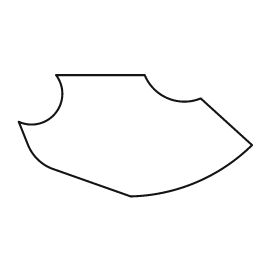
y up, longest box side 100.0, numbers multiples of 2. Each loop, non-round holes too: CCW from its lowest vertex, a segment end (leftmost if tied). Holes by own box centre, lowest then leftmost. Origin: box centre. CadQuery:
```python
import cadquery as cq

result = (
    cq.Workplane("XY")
    .moveTo(-2.0, -26.0)
    .threePointArc((26.0, -20.0), (50.0, -4.0))
    .lineTo(28.0, 16.0)
    .threePointArc((14.0, 16.0), (4.0, 26.0))
    .lineTo(-34.0, 26.0)
    .threePointArc((-34.0, 10.0), (-50.0, 6.0))
    .lineTo(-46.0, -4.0)
    .threePointArc((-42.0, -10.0), (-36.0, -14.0))
    .close()
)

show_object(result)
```